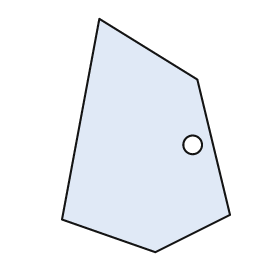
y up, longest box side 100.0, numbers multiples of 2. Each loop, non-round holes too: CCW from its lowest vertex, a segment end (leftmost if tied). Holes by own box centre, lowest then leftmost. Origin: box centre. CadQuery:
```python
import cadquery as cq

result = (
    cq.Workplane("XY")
    .moveTo(4.0, -50.0)
    .lineTo(36.0, -34.0)
    .lineTo(22.0, 24.0)
    .lineTo(-20.0, 50.0)
    .lineTo(-36.0, -36.0)
    .close()
    .moveTo(20.0, -4.0)
    .circle(4.0)
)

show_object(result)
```